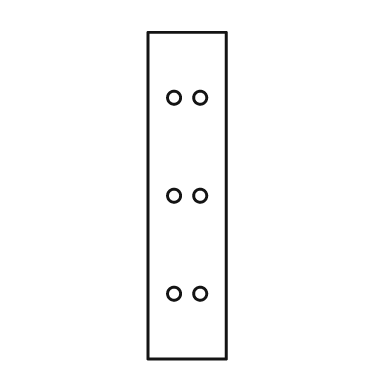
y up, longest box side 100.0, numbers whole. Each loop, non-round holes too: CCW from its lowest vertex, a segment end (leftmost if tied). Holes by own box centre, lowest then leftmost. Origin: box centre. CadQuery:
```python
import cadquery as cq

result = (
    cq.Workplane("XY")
    .moveTo(-12.0, -50.0)
    .lineTo(12.0, -50.0)
    .lineTo(12.0, 50.0)
    .lineTo(-12.0, 50.0)
    .close()
    .moveTo(-4.0, -30.0)
    .circle(2.0)
    .moveTo(4.0, -30.0)
    .circle(2.0)
    .moveTo(-4.0, 0.0)
    .circle(2.0)
    .moveTo(4.0, 0.0)
    .circle(2.0)
    .moveTo(-4.0, 30.0)
    .circle(2.0)
    .moveTo(4.0, 30.0)
    .circle(2.0)
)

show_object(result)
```